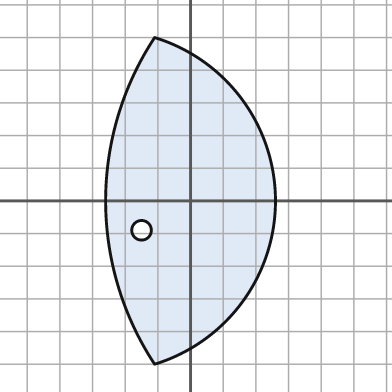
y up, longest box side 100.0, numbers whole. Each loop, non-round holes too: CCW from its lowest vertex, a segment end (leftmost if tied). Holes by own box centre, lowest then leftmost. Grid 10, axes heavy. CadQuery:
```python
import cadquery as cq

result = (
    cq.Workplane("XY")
    .moveTo(-11.0, -50.0)
    .threePointArc((26.0, 0.0), (-11.0, 50.0))
    .threePointArc((-26.0, 0.0), (-11.0, -50.0))
    .close()
    .moveTo(-15.0, -9.0)
    .circle(3.0)
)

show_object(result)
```